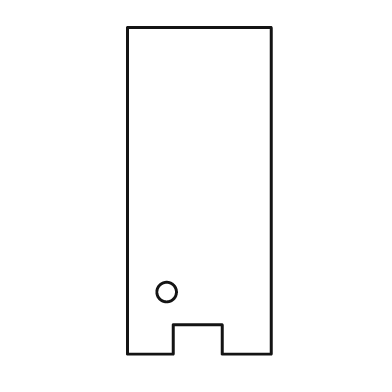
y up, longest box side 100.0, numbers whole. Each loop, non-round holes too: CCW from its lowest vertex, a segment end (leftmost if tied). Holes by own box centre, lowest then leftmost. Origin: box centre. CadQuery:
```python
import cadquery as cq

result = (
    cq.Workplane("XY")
    .moveTo(-22.0, -50.0)
    .lineTo(-8.0, -50.0)
    .lineTo(-8.0, -41.0)
    .lineTo(7.0, -41.0)
    .lineTo(7.0, -50.0)
    .lineTo(22.0, -50.0)
    .lineTo(22.0, 50.0)
    .lineTo(-22.0, 50.0)
    .close()
    .moveTo(-10.0, -31.0)
    .circle(3.0)
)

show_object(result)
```